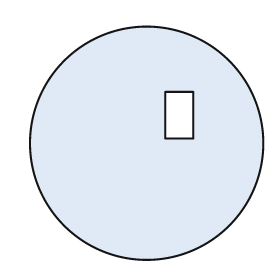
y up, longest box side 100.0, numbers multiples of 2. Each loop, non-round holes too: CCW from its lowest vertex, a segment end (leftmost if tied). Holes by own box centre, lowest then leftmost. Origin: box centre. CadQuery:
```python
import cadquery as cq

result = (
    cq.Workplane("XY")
    .moveTo(0.0, 0.0)
    .circle(50.0)
    .moveTo(8.0, 2.0)
    .lineTo(20.0, 2.0)
    .lineTo(20.0, 22.0)
    .lineTo(8.0, 22.0)
    .close()
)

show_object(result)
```